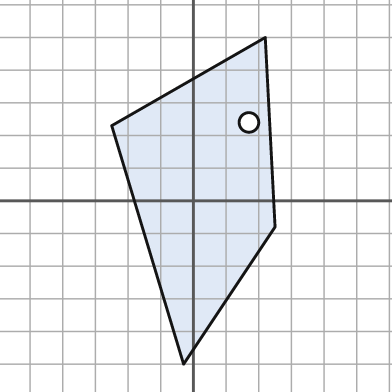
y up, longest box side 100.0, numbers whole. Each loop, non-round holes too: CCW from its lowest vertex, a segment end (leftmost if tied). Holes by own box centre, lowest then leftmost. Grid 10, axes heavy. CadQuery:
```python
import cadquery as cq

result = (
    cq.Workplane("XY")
    .moveTo(-3.0, -50.0)
    .lineTo(25.0, -8.0)
    .lineTo(22.0, 50.0)
    .lineTo(-25.0, 23.0)
    .close()
    .moveTo(17.0, 24.0)
    .circle(3.0)
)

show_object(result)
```